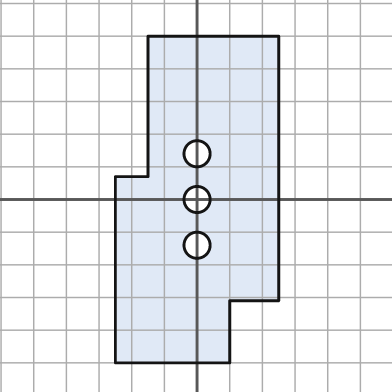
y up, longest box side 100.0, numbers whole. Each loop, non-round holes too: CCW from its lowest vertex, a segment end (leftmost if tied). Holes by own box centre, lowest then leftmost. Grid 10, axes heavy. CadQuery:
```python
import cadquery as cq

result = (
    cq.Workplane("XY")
    .moveTo(-25.0, -50.0)
    .lineTo(10.0, -50.0)
    .lineTo(10.0, -31.0)
    .lineTo(25.0, -31.0)
    .lineTo(25.0, 50.0)
    .lineTo(-15.0, 50.0)
    .lineTo(-15.0, 7.0)
    .lineTo(-25.0, 7.0)
    .close()
    .moveTo(0.0, -14.0)
    .circle(4.0)
    .moveTo(0.0, 0.0)
    .circle(4.0)
    .moveTo(0.0, 14.0)
    .circle(4.0)
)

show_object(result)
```